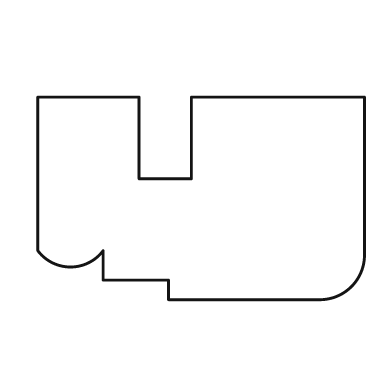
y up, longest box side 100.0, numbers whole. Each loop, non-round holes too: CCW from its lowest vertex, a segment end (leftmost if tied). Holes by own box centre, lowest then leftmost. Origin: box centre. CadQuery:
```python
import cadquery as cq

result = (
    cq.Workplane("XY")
    .moveTo(-10.0, -31.0)
    .lineTo(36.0, -31.0)
    .threePointArc((46.0, -27.0), (50.0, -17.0))
    .lineTo(50.0, 31.0)
    .lineTo(-3.0, 31.0)
    .lineTo(-3.0, 6.0)
    .lineTo(-19.0, 6.0)
    .lineTo(-19.0, 31.0)
    .lineTo(-50.0, 31.0)
    .lineTo(-50.0, -16.0)
    .threePointArc((-40.0, -21.0), (-30.0, -16.0))
    .lineTo(-30.0, -25.0)
    .lineTo(-10.0, -25.0)
    .close()
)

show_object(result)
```